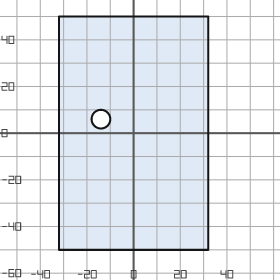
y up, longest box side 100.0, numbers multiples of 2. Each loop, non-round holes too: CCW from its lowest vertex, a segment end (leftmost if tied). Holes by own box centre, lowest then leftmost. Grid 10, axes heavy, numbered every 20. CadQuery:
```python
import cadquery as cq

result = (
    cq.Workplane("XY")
    .moveTo(-32.0, -50.0)
    .lineTo(32.0, -50.0)
    .lineTo(32.0, 50.0)
    .lineTo(-32.0, 50.0)
    .close()
    .moveTo(-14.0, 6.0)
    .circle(4.0)
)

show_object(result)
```